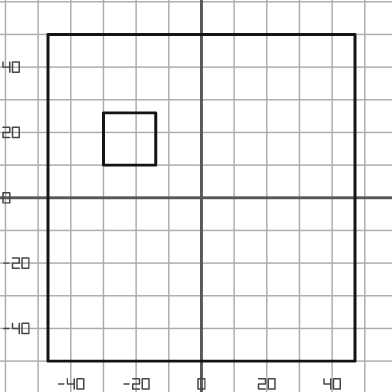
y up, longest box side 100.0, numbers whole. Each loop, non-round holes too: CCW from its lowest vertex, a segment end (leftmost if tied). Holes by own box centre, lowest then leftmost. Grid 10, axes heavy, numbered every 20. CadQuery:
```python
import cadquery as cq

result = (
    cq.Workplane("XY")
    .moveTo(-47.0, -50.0)
    .lineTo(47.0, -50.0)
    .lineTo(47.0, 50.0)
    .lineTo(-47.0, 50.0)
    .close()
    .moveTo(-30.0, 10.0)
    .lineTo(-14.0, 10.0)
    .lineTo(-14.0, 26.0)
    .lineTo(-30.0, 26.0)
    .close()
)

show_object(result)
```